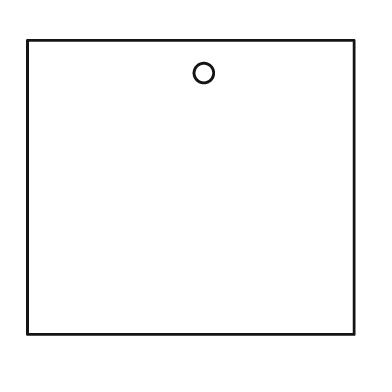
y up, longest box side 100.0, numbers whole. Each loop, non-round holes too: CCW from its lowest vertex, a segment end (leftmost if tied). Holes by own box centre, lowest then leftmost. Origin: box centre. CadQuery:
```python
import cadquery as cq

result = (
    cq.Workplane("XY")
    .moveTo(-50.0, -45.0)
    .lineTo(50.0, -45.0)
    .lineTo(50.0, 45.0)
    .lineTo(-50.0, 45.0)
    .close()
    .moveTo(4.0, 35.0)
    .circle(3.0)
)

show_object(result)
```